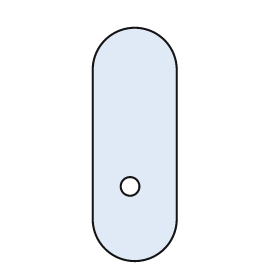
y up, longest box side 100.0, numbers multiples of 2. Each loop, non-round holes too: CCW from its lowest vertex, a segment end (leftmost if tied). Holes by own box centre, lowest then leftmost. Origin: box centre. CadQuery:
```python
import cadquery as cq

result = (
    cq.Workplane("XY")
    .moveTo(-18.0, -32.0)
    .threePointArc((0.0, -50.0), (18.0, -32.0))
    .lineTo(18.0, 32.0)
    .threePointArc((0.0, 50.0), (-18.0, 32.0))
    .close()
    .moveTo(-2.0, -18.0)
    .circle(4.0)
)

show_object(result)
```